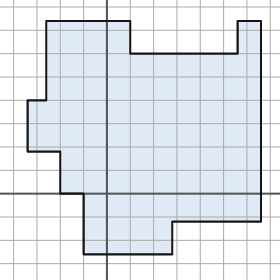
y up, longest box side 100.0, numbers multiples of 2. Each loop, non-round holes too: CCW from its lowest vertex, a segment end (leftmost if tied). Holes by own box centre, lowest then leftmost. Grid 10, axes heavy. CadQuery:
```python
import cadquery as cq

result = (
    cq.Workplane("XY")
    .moveTo(-10.0, -26.0)
    .lineTo(28.0, -26.0)
    .lineTo(28.0, -12.0)
    .lineTo(66.0, -12.0)
    .lineTo(66.0, 74.0)
    .lineTo(56.0, 74.0)
    .lineTo(56.0, 60.0)
    .lineTo(10.0, 60.0)
    .lineTo(10.0, 74.0)
    .lineTo(-26.0, 74.0)
    .lineTo(-26.0, 40.0)
    .lineTo(-34.0, 40.0)
    .lineTo(-34.0, 18.0)
    .lineTo(-20.0, 18.0)
    .lineTo(-20.0, 0.0)
    .lineTo(-10.0, 0.0)
    .close()
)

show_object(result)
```